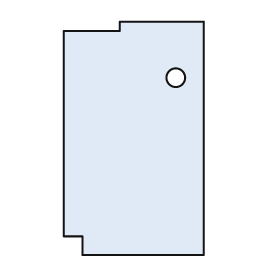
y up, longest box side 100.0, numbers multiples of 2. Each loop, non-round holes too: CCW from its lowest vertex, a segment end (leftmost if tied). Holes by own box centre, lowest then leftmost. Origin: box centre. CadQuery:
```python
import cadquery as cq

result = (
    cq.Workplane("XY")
    .moveTo(-22.0, -50.0)
    .lineTo(30.0, -50.0)
    .lineTo(30.0, 50.0)
    .lineTo(-6.0, 50.0)
    .lineTo(-6.0, 46.0)
    .lineTo(-30.0, 46.0)
    .lineTo(-30.0, -42.0)
    .lineTo(-22.0, -42.0)
    .close()
    .moveTo(18.0, 26.0)
    .circle(4.0)
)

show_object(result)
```